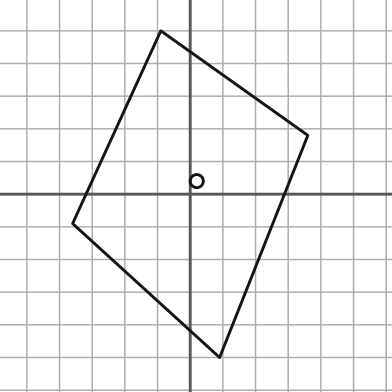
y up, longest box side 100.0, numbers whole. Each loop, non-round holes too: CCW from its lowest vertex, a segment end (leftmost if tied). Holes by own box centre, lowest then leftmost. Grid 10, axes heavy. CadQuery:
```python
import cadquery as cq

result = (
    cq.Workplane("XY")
    .moveTo(9.0, -50.0)
    .lineTo(36.0, 18.0)
    .lineTo(-9.0, 50.0)
    .lineTo(-36.0, -9.0)
    .close()
    .moveTo(2.0, 4.0)
    .circle(2.0)
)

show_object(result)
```